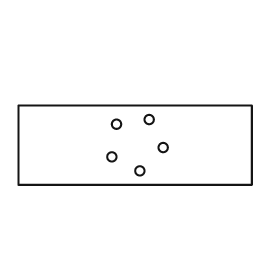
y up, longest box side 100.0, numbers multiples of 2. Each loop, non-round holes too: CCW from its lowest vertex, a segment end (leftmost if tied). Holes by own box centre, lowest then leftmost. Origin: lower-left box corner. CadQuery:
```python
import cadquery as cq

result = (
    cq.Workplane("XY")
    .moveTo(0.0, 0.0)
    .lineTo(100.0, 0.0)
    .lineTo(100.0, 34.0)
    .lineTo(0.0, 34.0)
    .close()
    .moveTo(52.0, 6.0)
    .circle(2.0)
    .moveTo(40.0, 12.0)
    .circle(2.0)
    .moveTo(62.0, 16.0)
    .circle(2.0)
    .moveTo(42.0, 26.0)
    .circle(2.0)
    .moveTo(56.0, 28.0)
    .circle(2.0)
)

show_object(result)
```